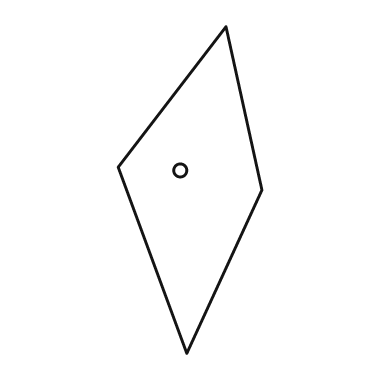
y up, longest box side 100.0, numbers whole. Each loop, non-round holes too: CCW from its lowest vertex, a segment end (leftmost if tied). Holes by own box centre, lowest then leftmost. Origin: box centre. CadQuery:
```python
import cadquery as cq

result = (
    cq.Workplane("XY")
    .moveTo(-1.0, -50.0)
    .lineTo(22.0, 0.0)
    .lineTo(11.0, 50.0)
    .lineTo(-22.0, 7.0)
    .close()
    .moveTo(-3.0, 6.0)
    .circle(2.0)
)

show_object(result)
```